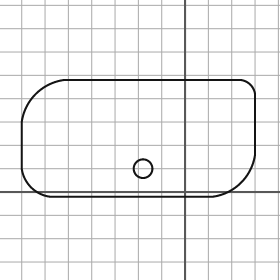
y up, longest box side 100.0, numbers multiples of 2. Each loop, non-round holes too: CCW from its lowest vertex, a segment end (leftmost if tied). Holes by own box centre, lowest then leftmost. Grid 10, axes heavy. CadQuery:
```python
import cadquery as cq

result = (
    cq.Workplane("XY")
    .moveTo(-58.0, -2.0)
    .lineTo(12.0, -2.0)
    .threePointArc((24.0, 4.0), (30.0, 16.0))
    .lineTo(30.0, 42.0)
    .threePointArc((28.0, 46.0), (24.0, 48.0))
    .lineTo(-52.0, 48.0)
    .threePointArc((-64.0, 42.0), (-70.0, 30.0))
    .lineTo(-70.0, 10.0)
    .threePointArc((-66.0, 2.0), (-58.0, -2.0))
    .close()
    .moveTo(-18.0, 10.0)
    .circle(4.0)
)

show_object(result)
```